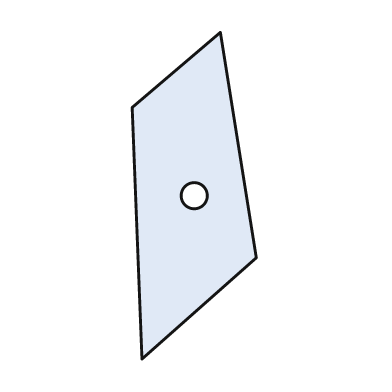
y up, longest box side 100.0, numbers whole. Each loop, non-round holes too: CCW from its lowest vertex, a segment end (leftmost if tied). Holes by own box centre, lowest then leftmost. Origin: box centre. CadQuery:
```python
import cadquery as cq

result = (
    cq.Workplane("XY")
    .moveTo(-16.0, -50.0)
    .lineTo(19.0, -19.0)
    .lineTo(8.0, 50.0)
    .lineTo(-19.0, 27.0)
    .close()
    .moveTo(0.0, 0.0)
    .circle(4.0)
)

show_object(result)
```